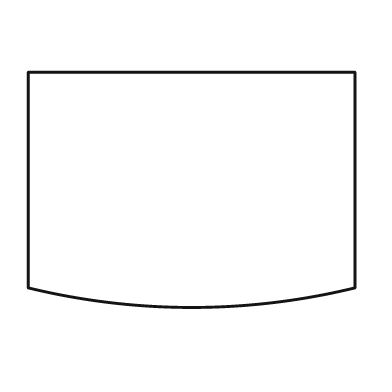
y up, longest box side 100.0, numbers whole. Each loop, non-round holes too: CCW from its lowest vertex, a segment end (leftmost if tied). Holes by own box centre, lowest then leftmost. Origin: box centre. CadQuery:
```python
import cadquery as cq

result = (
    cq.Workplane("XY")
    .moveTo(-50.0, -30.0)
    .threePointArc((0.0, -36.0), (50.0, -30.0))
    .lineTo(50.0, 36.0)
    .lineTo(-50.0, 36.0)
    .close()
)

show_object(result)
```